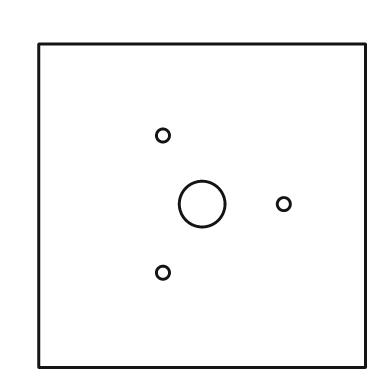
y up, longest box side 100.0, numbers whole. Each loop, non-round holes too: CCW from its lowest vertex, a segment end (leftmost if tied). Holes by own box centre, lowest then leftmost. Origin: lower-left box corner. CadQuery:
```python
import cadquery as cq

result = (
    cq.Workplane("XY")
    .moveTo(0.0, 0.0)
    .lineTo(100.0, 0.0)
    .lineTo(100.0, 99.0)
    .lineTo(0.0, 99.0)
    .close()
    .moveTo(38.0, 29.0)
    .circle(2.0)
    .moveTo(50.0, 50.0)
    .circle(7.0)
    .moveTo(75.0, 50.0)
    .circle(2.0)
    .moveTo(38.0, 71.0)
    .circle(2.0)
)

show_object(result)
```